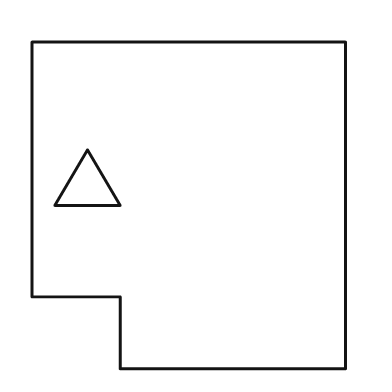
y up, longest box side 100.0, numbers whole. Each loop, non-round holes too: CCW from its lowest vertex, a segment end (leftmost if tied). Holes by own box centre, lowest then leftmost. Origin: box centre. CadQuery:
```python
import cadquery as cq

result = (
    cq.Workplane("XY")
    .moveTo(-21.0, -50.0)
    .lineTo(48.0, -50.0)
    .lineTo(48.0, 50.0)
    .lineTo(-48.0, 50.0)
    .lineTo(-48.0, -28.0)
    .lineTo(-21.0, -28.0)
    .close()
    .moveTo(-41.0, 0.0)
    .lineTo(-21.0, 0.0)
    .lineTo(-31.0, 17.0)
    .close()
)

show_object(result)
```